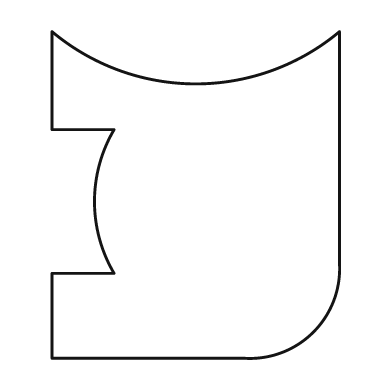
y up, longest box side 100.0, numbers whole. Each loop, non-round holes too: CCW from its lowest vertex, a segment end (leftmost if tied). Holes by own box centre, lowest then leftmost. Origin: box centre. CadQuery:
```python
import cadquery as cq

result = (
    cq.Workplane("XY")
    .moveTo(-44.0, -50.0)
    .lineTo(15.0, -50.0)
    .threePointArc((36.0, -42.0), (44.0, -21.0))
    .lineTo(44.0, 50.0)
    .threePointArc((0.0, 34.0), (-44.0, 50.0))
    .lineTo(-44.0, 20.0)
    .lineTo(-25.0, 20.0)
    .threePointArc((-31.0, -2.0), (-25.0, -24.0))
    .lineTo(-44.0, -24.0)
    .close()
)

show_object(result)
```